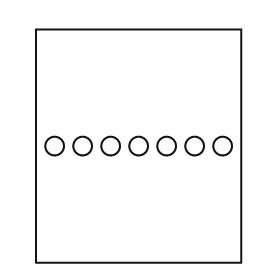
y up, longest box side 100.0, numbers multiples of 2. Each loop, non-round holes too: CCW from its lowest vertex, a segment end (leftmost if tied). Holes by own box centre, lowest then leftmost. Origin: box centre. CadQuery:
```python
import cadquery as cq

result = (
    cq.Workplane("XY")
    .moveTo(-44.0, -50.0)
    .lineTo(44.0, -50.0)
    .lineTo(44.0, 50.0)
    .lineTo(-44.0, 50.0)
    .close()
    .moveTo(-36.0, 0.0)
    .circle(4.0)
    .moveTo(-24.0, 0.0)
    .circle(4.0)
    .moveTo(-12.0, 0.0)
    .circle(4.0)
    .moveTo(0.0, 0.0)
    .circle(4.0)
    .moveTo(12.0, 0.0)
    .circle(4.0)
    .moveTo(24.0, 0.0)
    .circle(4.0)
    .moveTo(36.0, 0.0)
    .circle(4.0)
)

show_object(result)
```